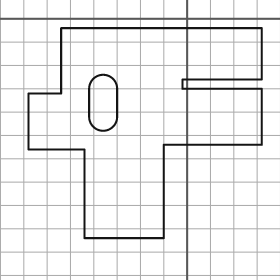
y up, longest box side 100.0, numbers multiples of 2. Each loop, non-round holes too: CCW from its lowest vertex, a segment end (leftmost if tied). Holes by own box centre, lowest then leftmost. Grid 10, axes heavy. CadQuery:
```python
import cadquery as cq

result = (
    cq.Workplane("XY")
    .moveTo(-44.0, -94.0)
    .lineTo(-10.0, -94.0)
    .lineTo(-10.0, -54.0)
    .lineTo(32.0, -54.0)
    .lineTo(32.0, -30.0)
    .lineTo(-2.0, -30.0)
    .lineTo(-2.0, -26.0)
    .lineTo(32.0, -26.0)
    .lineTo(32.0, -4.0)
    .lineTo(-54.0, -4.0)
    .lineTo(-54.0, -32.0)
    .lineTo(-68.0, -32.0)
    .lineTo(-68.0, -56.0)
    .lineTo(-44.0, -56.0)
    .close()
    .moveTo(-42.0, -42.0)
    .threePointArc((-36.0, -48.0), (-30.0, -42.0))
    .lineTo(-30.0, -30.0)
    .threePointArc((-36.0, -24.0), (-42.0, -30.0))
    .close()
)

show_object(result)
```